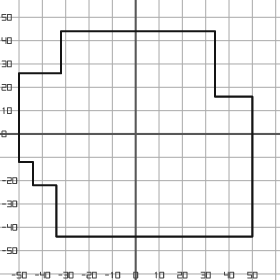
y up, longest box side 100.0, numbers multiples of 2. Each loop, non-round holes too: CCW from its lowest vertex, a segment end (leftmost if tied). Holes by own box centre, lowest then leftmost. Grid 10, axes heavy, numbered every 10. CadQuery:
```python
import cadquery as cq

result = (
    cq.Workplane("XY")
    .moveTo(-34.0, -44.0)
    .lineTo(50.0, -44.0)
    .lineTo(50.0, 16.0)
    .lineTo(34.0, 16.0)
    .lineTo(34.0, 44.0)
    .lineTo(-32.0, 44.0)
    .lineTo(-32.0, 26.0)
    .lineTo(-50.0, 26.0)
    .lineTo(-50.0, -12.0)
    .lineTo(-44.0, -12.0)
    .lineTo(-44.0, -22.0)
    .lineTo(-34.0, -22.0)
    .close()
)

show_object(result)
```